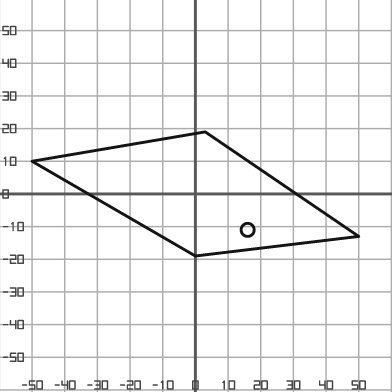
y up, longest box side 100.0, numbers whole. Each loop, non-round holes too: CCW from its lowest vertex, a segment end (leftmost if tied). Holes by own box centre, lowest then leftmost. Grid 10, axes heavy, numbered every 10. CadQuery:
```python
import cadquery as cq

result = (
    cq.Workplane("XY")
    .moveTo(0.0, -19.0)
    .lineTo(50.0, -13.0)
    .lineTo(3.0, 19.0)
    .lineTo(-50.0, 10.0)
    .close()
    .moveTo(16.0, -11.0)
    .circle(2.0)
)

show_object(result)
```